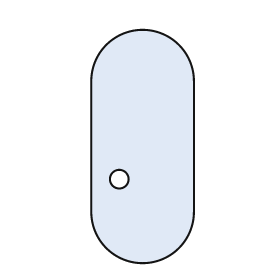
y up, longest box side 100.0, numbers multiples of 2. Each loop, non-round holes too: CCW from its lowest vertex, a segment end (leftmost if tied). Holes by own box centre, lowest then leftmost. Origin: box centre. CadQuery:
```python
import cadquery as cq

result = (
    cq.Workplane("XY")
    .moveTo(-22.0, -28.0)
    .threePointArc((0.0, -50.0), (22.0, -28.0))
    .lineTo(22.0, 28.0)
    .threePointArc((0.0, 50.0), (-22.0, 28.0))
    .close()
    .moveTo(-10.0, -14.0)
    .circle(4.0)
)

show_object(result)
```